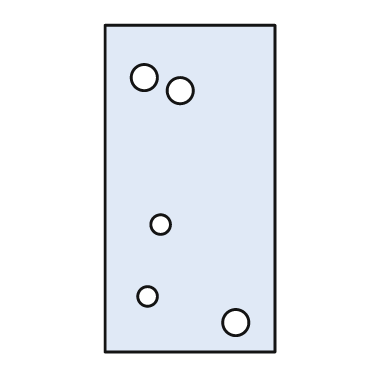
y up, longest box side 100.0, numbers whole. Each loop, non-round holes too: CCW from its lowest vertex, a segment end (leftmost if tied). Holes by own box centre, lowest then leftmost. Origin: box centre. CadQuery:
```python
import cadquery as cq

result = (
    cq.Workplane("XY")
    .moveTo(-26.0, -50.0)
    .lineTo(26.0, -50.0)
    .lineTo(26.0, 50.0)
    .lineTo(-26.0, 50.0)
    .close()
    .moveTo(14.0, -41.0)
    .circle(4.0)
    .moveTo(-13.0, -33.0)
    .circle(3.0)
    .moveTo(-9.0, -11.0)
    .circle(3.0)
    .moveTo(-3.0, 30.0)
    .circle(4.0)
    .moveTo(-14.0, 34.0)
    .circle(4.0)
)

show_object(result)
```